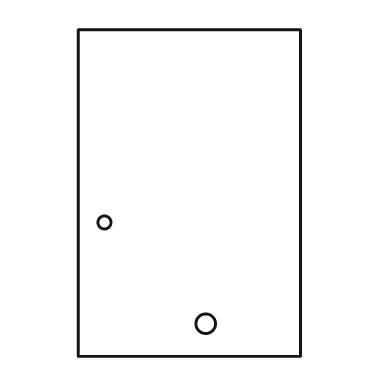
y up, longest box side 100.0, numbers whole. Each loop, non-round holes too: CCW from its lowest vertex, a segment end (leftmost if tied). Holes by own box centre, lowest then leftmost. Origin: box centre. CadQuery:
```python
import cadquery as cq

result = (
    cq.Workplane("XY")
    .moveTo(-34.0, -50.0)
    .lineTo(34.0, -50.0)
    .lineTo(34.0, 50.0)
    .lineTo(-34.0, 50.0)
    .close()
    .moveTo(5.0, -40.0)
    .circle(3.0)
    .moveTo(-26.0, -9.0)
    .circle(2.0)
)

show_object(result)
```